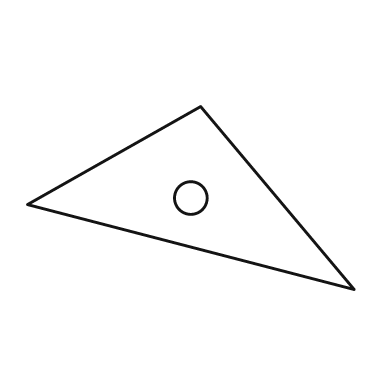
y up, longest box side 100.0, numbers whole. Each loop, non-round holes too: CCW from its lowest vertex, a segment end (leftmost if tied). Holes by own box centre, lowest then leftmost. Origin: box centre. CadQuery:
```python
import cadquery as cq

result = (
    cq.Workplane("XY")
    .moveTo(50.0, -28.0)
    .lineTo(3.0, 28.0)
    .lineTo(-50.0, -2.0)
    .close()
    .moveTo(0.0, 0.0)
    .circle(5.0)
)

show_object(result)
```